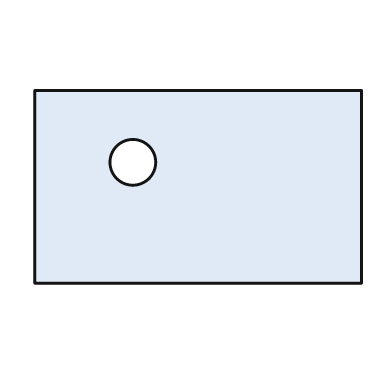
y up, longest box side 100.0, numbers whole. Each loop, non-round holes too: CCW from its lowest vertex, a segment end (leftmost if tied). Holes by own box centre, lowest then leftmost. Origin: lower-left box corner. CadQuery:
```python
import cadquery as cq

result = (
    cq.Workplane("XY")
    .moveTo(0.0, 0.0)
    .lineTo(100.0, 0.0)
    .lineTo(100.0, 59.0)
    .lineTo(0.0, 59.0)
    .close()
    .moveTo(30.0, 37.0)
    .circle(7.0)
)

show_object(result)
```